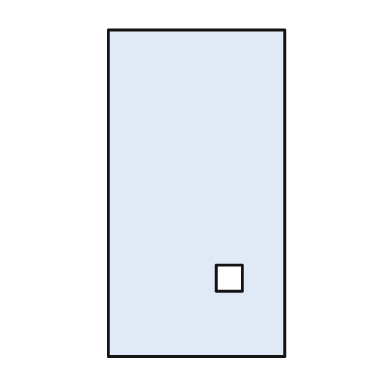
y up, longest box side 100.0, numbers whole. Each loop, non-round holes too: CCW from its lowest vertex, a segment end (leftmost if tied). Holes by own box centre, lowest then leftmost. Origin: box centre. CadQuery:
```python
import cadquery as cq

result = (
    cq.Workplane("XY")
    .moveTo(-27.0, -50.0)
    .lineTo(27.0, -50.0)
    .lineTo(27.0, 50.0)
    .lineTo(-27.0, 50.0)
    .close()
    .moveTo(6.0, -30.0)
    .lineTo(14.0, -30.0)
    .lineTo(14.0, -22.0)
    .lineTo(6.0, -22.0)
    .close()
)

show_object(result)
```